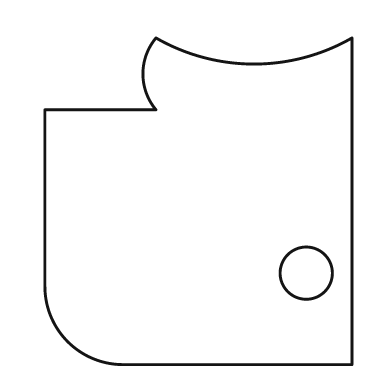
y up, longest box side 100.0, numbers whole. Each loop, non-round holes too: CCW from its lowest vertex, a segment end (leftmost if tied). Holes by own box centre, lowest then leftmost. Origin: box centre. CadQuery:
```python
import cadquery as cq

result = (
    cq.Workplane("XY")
    .moveTo(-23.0, -50.0)
    .lineTo(47.0, -50.0)
    .lineTo(47.0, 50.0)
    .threePointArc((17.0, 42.0), (-13.0, 50.0))
    .threePointArc((-17.0, 39.0), (-13.0, 28.0))
    .lineTo(-47.0, 28.0)
    .lineTo(-47.0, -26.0)
    .threePointArc((-40.0, -43.0), (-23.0, -50.0))
    .close()
    .moveTo(33.0, -22.0)
    .circle(8.0)
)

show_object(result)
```